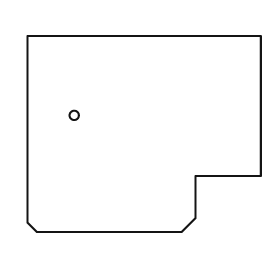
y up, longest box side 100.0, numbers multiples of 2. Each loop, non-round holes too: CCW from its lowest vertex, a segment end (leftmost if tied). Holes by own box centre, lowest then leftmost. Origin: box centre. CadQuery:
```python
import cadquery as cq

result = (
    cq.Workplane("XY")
    .moveTo(-46.0, -42.0)
    .lineTo(16.0, -42.0)
    .lineTo(22.0, -36.0)
    .lineTo(22.0, -18.0)
    .lineTo(50.0, -18.0)
    .lineTo(50.0, 42.0)
    .lineTo(-50.0, 42.0)
    .lineTo(-50.0, -38.0)
    .close()
    .moveTo(-30.0, 8.0)
    .circle(2.0)
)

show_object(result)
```